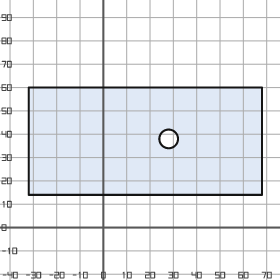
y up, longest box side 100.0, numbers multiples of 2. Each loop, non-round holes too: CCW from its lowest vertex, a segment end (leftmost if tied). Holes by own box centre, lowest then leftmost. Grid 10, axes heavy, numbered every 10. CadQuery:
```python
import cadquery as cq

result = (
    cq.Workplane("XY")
    .moveTo(-32.0, 14.0)
    .lineTo(68.0, 14.0)
    .lineTo(68.0, 60.0)
    .lineTo(-32.0, 60.0)
    .close()
    .moveTo(28.0, 38.0)
    .circle(4.0)
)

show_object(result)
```